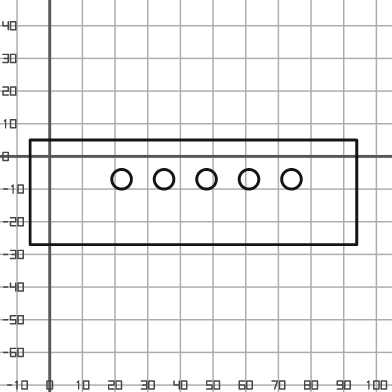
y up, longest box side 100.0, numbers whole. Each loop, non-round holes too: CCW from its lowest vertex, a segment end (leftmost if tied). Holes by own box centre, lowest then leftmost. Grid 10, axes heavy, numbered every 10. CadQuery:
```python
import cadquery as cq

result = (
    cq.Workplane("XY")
    .moveTo(-6.0, -27.0)
    .lineTo(94.0, -27.0)
    .lineTo(94.0, 5.0)
    .lineTo(-6.0, 5.0)
    .close()
    .moveTo(22.0, -7.0)
    .circle(3.0)
    .moveTo(35.0, -7.0)
    .circle(3.0)
    .moveTo(48.0, -7.0)
    .circle(3.0)
    .moveTo(61.0, -7.0)
    .circle(3.0)
    .moveTo(74.0, -7.0)
    .circle(3.0)
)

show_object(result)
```